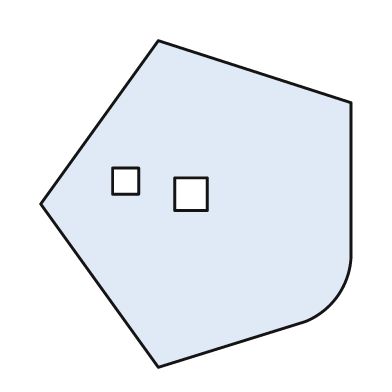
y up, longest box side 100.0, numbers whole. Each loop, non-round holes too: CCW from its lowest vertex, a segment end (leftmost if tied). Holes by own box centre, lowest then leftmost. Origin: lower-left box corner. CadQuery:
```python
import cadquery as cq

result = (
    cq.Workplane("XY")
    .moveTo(36.0, 0.0)
    .lineTo(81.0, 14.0)
    .threePointArc((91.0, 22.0), (95.0, 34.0))
    .lineTo(95.0, 81.0)
    .lineTo(36.0, 100.0)
    .lineTo(0.0, 50.0)
    .close()
    .moveTo(41.0, 48.0)
    .lineTo(51.0, 48.0)
    .lineTo(51.0, 58.0)
    .lineTo(41.0, 58.0)
    .close()
    .moveTo(22.0, 53.0)
    .lineTo(30.0, 53.0)
    .lineTo(30.0, 61.0)
    .lineTo(22.0, 61.0)
    .close()
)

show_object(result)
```